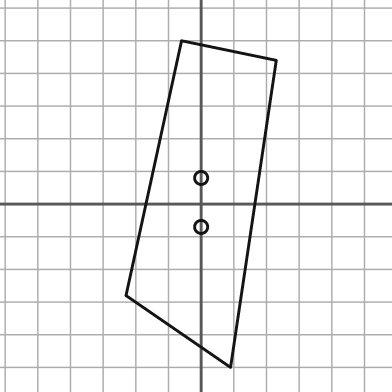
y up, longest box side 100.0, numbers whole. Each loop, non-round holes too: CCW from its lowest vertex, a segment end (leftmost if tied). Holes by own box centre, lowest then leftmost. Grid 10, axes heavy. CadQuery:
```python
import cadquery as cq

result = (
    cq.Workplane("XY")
    .moveTo(9.0, -50.0)
    .lineTo(23.0, 44.0)
    .lineTo(-6.0, 50.0)
    .lineTo(-23.0, -28.0)
    .close()
    .moveTo(0.0, -7.0)
    .circle(2.0)
    .moveTo(0.0, 8.0)
    .circle(2.0)
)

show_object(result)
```